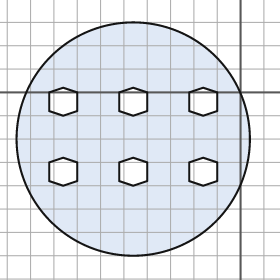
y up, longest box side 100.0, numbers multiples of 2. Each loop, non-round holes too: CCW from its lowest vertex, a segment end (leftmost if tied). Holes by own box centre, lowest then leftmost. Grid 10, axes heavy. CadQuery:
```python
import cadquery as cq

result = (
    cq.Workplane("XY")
    .moveTo(-46.0, -20.0)
    .circle(50.0)
    .moveTo(-76.0, -40.0)
    .lineTo(-70.0, -38.0)
    .lineTo(-70.0, -30.0)
    .lineTo(-76.0, -28.0)
    .lineTo(-82.0, -30.0)
    .lineTo(-82.0, -38.0)
    .close()
    .moveTo(-46.0, -40.0)
    .lineTo(-40.0, -38.0)
    .lineTo(-40.0, -30.0)
    .lineTo(-46.0, -28.0)
    .lineTo(-52.0, -30.0)
    .lineTo(-52.0, -38.0)
    .close()
    .moveTo(-16.0, -40.0)
    .lineTo(-10.0, -38.0)
    .lineTo(-10.0, -30.0)
    .lineTo(-16.0, -28.0)
    .lineTo(-22.0, -30.0)
    .lineTo(-22.0, -38.0)
    .close()
    .moveTo(-76.0, -10.0)
    .lineTo(-70.0, -8.0)
    .lineTo(-70.0, 0.0)
    .lineTo(-76.0, 2.0)
    .lineTo(-82.0, 0.0)
    .lineTo(-82.0, -8.0)
    .close()
    .moveTo(-46.0, -10.0)
    .lineTo(-40.0, -8.0)
    .lineTo(-40.0, 0.0)
    .lineTo(-46.0, 2.0)
    .lineTo(-52.0, 0.0)
    .lineTo(-52.0, -8.0)
    .close()
    .moveTo(-16.0, -10.0)
    .lineTo(-10.0, -8.0)
    .lineTo(-10.0, 0.0)
    .lineTo(-16.0, 2.0)
    .lineTo(-22.0, 0.0)
    .lineTo(-22.0, -8.0)
    .close()
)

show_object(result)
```